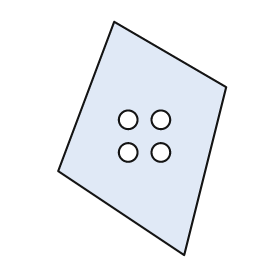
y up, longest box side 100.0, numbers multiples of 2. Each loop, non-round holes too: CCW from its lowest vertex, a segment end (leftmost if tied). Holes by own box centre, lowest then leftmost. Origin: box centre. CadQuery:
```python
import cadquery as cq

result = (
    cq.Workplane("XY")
    .moveTo(18.0, -50.0)
    .lineTo(36.0, 22.0)
    .lineTo(-12.0, 50.0)
    .lineTo(-36.0, -14.0)
    .close()
    .moveTo(-6.0, -6.0)
    .circle(4.0)
    .moveTo(8.0, -6.0)
    .circle(4.0)
    .moveTo(-6.0, 8.0)
    .circle(4.0)
    .moveTo(8.0, 8.0)
    .circle(4.0)
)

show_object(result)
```